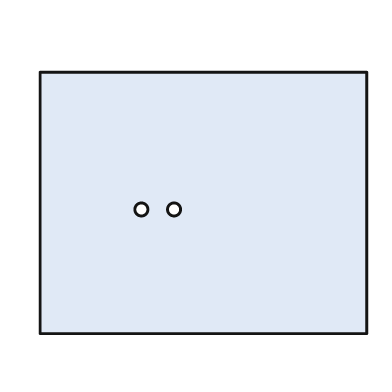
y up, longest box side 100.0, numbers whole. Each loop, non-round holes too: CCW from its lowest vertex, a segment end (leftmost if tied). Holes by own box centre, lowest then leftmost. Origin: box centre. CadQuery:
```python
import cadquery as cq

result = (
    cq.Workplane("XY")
    .moveTo(-50.0, -40.0)
    .lineTo(50.0, -40.0)
    .lineTo(50.0, 40.0)
    .lineTo(-50.0, 40.0)
    .close()
    .moveTo(-19.0, -2.0)
    .circle(2.0)
    .moveTo(-9.0, -2.0)
    .circle(2.0)
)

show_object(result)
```